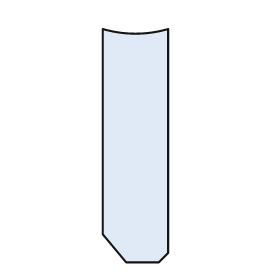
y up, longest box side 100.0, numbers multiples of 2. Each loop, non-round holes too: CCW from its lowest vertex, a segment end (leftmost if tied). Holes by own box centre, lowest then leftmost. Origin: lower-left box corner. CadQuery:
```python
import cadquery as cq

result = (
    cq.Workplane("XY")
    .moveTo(10.0, 0.0)
    .lineTo(24.0, 0.0)
    .lineTo(28.0, 4.0)
    .lineTo(28.0, 100.0)
    .threePointArc((14.0, 98.0), (0.0, 100.0))
    .lineTo(0.0, 12.0)
    .close()
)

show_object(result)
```